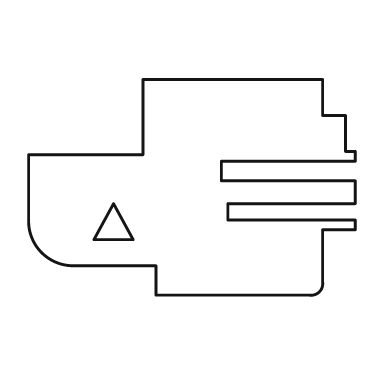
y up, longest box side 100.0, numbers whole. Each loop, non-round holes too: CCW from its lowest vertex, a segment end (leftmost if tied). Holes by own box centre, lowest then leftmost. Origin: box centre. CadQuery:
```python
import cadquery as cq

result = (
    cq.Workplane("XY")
    .moveTo(-11.0, -33.0)
    .lineTo(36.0, -33.0)
    .threePointArc((39.0, -32.0), (40.0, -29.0))
    .lineTo(40.0, -13.0)
    .lineTo(50.0, -13.0)
    .lineTo(50.0, -10.0)
    .lineTo(11.0, -10.0)
    .lineTo(11.0, -5.0)
    .lineTo(50.0, -5.0)
    .lineTo(50.0, 2.0)
    .lineTo(9.0, 2.0)
    .lineTo(9.0, 8.0)
    .lineTo(50.0, 8.0)
    .lineTo(50.0, 11.0)
    .lineTo(47.0, 11.0)
    .lineTo(47.0, 22.0)
    .lineTo(40.0, 22.0)
    .lineTo(40.0, 33.0)
    .lineTo(-15.0, 33.0)
    .lineTo(-15.0, 10.0)
    .lineTo(-50.0, 10.0)
    .lineTo(-50.0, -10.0)
    .threePointArc((-46.0, -20.0), (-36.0, -24.0))
    .lineTo(-11.0, -24.0)
    .close()
    .moveTo(-30.0, -16.0)
    .lineTo(-18.0, -16.0)
    .lineTo(-24.0, -5.0)
    .close()
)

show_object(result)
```